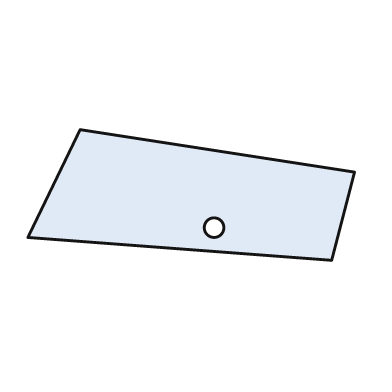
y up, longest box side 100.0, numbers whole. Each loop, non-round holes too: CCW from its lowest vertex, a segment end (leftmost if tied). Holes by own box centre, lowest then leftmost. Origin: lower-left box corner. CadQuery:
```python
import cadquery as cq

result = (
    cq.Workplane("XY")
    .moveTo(93.0, 0.0)
    .lineTo(100.0, 27.0)
    .lineTo(16.0, 40.0)
    .lineTo(0.0, 7.0)
    .close()
    .moveTo(57.0, 10.0)
    .circle(3.0)
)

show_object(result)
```